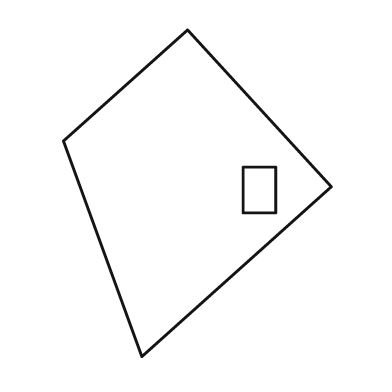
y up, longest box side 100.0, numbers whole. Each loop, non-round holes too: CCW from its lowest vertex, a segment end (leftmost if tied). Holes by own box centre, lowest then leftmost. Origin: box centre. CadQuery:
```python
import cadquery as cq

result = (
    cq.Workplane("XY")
    .moveTo(-17.0, -50.0)
    .lineTo(41.0, 2.0)
    .lineTo(-3.0, 50.0)
    .lineTo(-41.0, 16.0)
    .close()
    .moveTo(14.0, -6.0)
    .lineTo(24.0, -6.0)
    .lineTo(24.0, 8.0)
    .lineTo(14.0, 8.0)
    .close()
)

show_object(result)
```